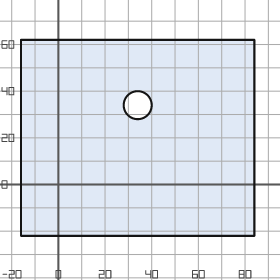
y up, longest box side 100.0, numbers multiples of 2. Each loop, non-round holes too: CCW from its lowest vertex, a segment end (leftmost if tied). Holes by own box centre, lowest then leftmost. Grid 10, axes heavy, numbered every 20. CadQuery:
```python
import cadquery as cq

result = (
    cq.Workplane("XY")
    .moveTo(-16.0, -22.0)
    .lineTo(84.0, -22.0)
    .lineTo(84.0, 62.0)
    .lineTo(-16.0, 62.0)
    .close()
    .moveTo(34.0, 34.0)
    .circle(6.0)
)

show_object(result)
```